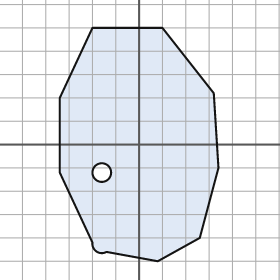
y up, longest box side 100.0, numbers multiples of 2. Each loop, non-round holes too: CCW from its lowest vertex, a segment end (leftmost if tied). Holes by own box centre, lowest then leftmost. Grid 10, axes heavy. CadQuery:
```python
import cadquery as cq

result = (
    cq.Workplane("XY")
    .moveTo(8.0, -50.0)
    .lineTo(26.0, -40.0)
    .lineTo(34.0, -10.0)
    .lineTo(32.0, 22.0)
    .lineTo(10.0, 50.0)
    .lineTo(-20.0, 50.0)
    .lineTo(-34.0, 20.0)
    .lineTo(-34.0, -12.0)
    .lineTo(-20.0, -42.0)
    .threePointArc((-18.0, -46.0), (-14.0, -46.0))
    .close()
    .moveTo(-16.0, -12.0)
    .circle(4.0)
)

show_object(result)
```